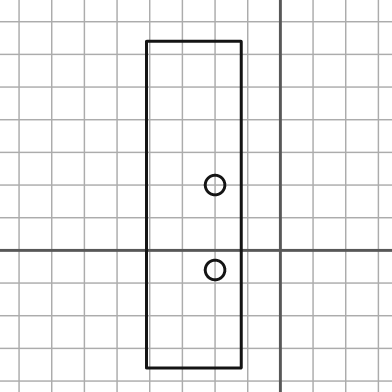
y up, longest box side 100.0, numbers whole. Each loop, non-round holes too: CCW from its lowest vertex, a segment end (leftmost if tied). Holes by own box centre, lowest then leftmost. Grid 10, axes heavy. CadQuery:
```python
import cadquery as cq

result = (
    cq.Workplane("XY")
    .moveTo(-41.0, -36.0)
    .lineTo(-12.0, -36.0)
    .lineTo(-12.0, 64.0)
    .lineTo(-41.0, 64.0)
    .close()
    .moveTo(-20.0, -6.0)
    .circle(3.0)
    .moveTo(-20.0, 20.0)
    .circle(3.0)
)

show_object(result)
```